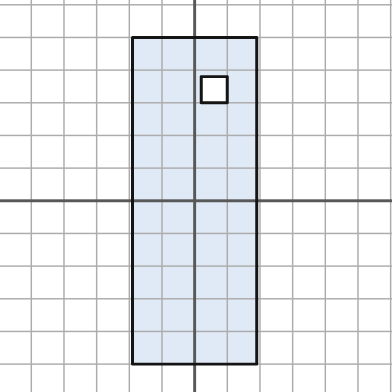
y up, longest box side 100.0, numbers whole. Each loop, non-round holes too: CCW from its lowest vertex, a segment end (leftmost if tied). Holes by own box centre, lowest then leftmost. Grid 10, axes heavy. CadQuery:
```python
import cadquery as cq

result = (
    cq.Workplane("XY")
    .moveTo(-19.0, -50.0)
    .lineTo(19.0, -50.0)
    .lineTo(19.0, 50.0)
    .lineTo(-19.0, 50.0)
    .close()
    .moveTo(2.0, 30.0)
    .lineTo(10.0, 30.0)
    .lineTo(10.0, 38.0)
    .lineTo(2.0, 38.0)
    .close()
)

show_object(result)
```